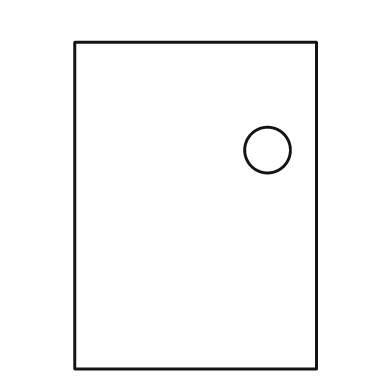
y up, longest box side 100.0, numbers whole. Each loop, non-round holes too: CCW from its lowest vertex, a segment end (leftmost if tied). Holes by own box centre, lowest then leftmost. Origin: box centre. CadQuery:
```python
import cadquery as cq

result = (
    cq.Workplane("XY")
    .moveTo(-37.0, -50.0)
    .lineTo(37.0, -50.0)
    .lineTo(37.0, 50.0)
    .lineTo(-37.0, 50.0)
    .close()
    .moveTo(22.0, 17.0)
    .circle(7.0)
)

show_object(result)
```